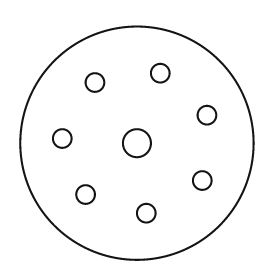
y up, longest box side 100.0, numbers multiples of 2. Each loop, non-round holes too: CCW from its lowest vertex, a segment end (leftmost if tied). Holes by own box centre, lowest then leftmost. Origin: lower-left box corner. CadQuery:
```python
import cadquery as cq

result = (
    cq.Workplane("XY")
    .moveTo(50.0, 50.0)
    .circle(50.0)
    .moveTo(54.0, 20.0)
    .circle(4.0)
    .moveTo(28.0, 28.0)
    .circle(4.0)
    .moveTo(78.0, 34.0)
    .circle(4.0)
    .moveTo(50.0, 50.0)
    .circle(6.0)
    .moveTo(18.0, 52.0)
    .circle(4.0)
    .moveTo(80.0, 62.0)
    .circle(4.0)
    .moveTo(32.0, 76.0)
    .circle(4.0)
    .moveTo(60.0, 80.0)
    .circle(4.0)
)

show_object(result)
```